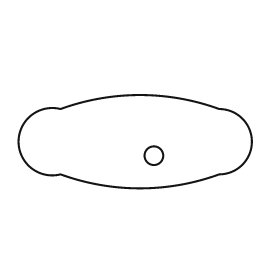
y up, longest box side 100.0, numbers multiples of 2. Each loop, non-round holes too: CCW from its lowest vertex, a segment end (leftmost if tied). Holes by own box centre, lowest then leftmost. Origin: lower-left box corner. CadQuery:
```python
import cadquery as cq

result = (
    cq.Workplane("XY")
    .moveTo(18.0, 6.0)
    .threePointArc((52.0, 0.0), (86.0, 6.0))
    .threePointArc((100.0, 20.0), (86.0, 34.0))
    .threePointArc((52.0, 40.0), (18.0, 34.0))
    .threePointArc((0.0, 20.0), (18.0, 6.0))
    .close()
    .moveTo(58.0, 14.0)
    .circle(4.0)
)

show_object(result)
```